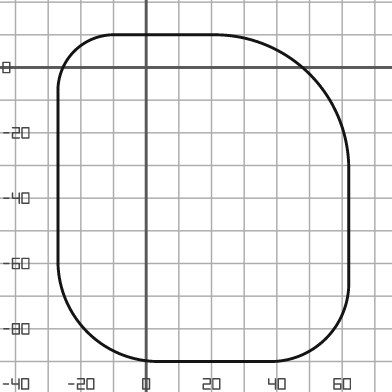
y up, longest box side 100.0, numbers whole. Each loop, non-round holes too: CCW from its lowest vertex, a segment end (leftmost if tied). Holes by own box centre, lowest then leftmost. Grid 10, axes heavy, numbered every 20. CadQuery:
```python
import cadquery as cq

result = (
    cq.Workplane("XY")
    .moveTo(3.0, -90.0)
    .lineTo(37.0, -90.0)
    .threePointArc((55.0, -83.0), (62.0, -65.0))
    .lineTo(62.0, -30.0)
    .threePointArc((50.0, -2.0), (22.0, 10.0))
    .lineTo(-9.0, 10.0)
    .threePointArc((-22.0, 5.0), (-27.0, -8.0))
    .lineTo(-27.0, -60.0)
    .threePointArc((-18.0, -81.0), (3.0, -90.0))
    .close()
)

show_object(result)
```